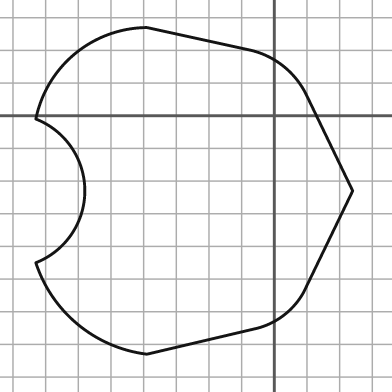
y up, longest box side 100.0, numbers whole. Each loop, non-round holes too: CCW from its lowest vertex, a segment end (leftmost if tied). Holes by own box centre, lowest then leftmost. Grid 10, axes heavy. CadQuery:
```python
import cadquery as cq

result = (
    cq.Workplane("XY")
    .moveTo(-39.0, -73.0)
    .lineTo(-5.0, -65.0)
    .threePointArc((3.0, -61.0), (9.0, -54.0))
    .lineTo(24.0, -23.0)
    .lineTo(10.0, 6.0)
    .threePointArc((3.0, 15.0), (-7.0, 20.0))
    .lineTo(-39.0, 27.0)
    .threePointArc((-61.0, 19.0), (-73.0, -1.0))
    .threePointArc((-58.0, -23.0), (-73.0, -45.0))
    .threePointArc((-60.0, -64.0), (-39.0, -73.0))
    .close()
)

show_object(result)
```